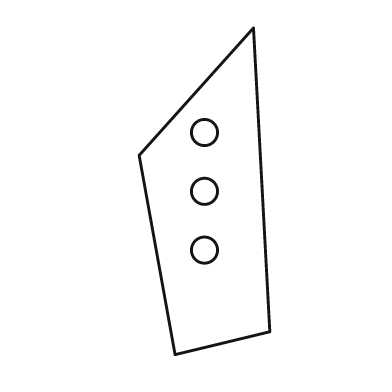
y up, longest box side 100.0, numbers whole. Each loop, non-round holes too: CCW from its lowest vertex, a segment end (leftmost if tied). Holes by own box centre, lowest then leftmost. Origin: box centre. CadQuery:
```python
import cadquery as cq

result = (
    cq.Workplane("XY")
    .moveTo(-9.0, -50.0)
    .lineTo(20.0, -43.0)
    .lineTo(15.0, 50.0)
    .lineTo(-20.0, 11.0)
    .close()
    .moveTo(0.0, -18.0)
    .circle(4.0)
    .moveTo(0.0, 0.0)
    .circle(4.0)
    .moveTo(0.0, 18.0)
    .circle(4.0)
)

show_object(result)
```